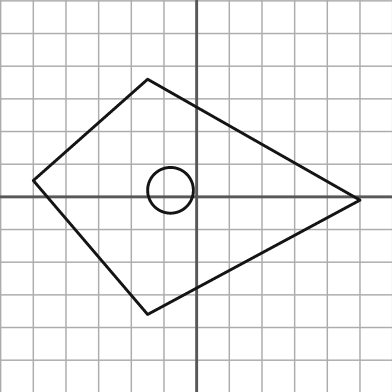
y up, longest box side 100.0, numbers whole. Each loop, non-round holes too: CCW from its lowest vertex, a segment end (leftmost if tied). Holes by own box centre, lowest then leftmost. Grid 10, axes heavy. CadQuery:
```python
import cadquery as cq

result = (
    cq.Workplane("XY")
    .moveTo(-15.0, -36.0)
    .lineTo(50.0, -1.0)
    .lineTo(-15.0, 36.0)
    .lineTo(-50.0, 5.0)
    .close()
    .moveTo(-8.0, 2.0)
    .circle(7.0)
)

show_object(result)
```